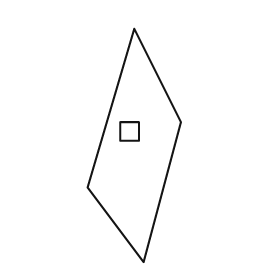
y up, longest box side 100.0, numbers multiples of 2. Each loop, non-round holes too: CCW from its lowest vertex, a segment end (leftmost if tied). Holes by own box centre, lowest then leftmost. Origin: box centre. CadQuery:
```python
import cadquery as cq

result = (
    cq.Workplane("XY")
    .moveTo(4.0, -50.0)
    .lineTo(20.0, 10.0)
    .lineTo(0.0, 50.0)
    .lineTo(-20.0, -18.0)
    .close()
    .moveTo(-6.0, 2.0)
    .lineTo(2.0, 2.0)
    .lineTo(2.0, 10.0)
    .lineTo(-6.0, 10.0)
    .close()
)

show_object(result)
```